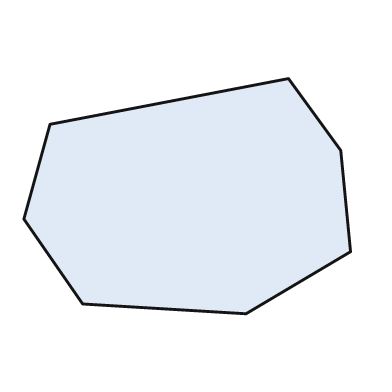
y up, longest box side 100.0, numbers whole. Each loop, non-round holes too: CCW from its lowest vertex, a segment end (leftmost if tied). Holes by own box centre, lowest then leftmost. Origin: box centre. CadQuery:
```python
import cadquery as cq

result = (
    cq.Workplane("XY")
    .moveTo(18.0, -36.0)
    .lineTo(50.0, -17.0)
    .lineTo(47.0, 14.0)
    .lineTo(31.0, 36.0)
    .lineTo(-42.0, 22.0)
    .lineTo(-50.0, -7.0)
    .lineTo(-32.0, -33.0)
    .close()
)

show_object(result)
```